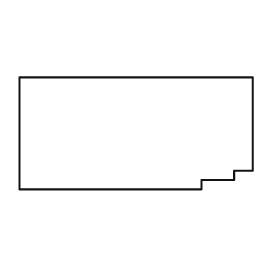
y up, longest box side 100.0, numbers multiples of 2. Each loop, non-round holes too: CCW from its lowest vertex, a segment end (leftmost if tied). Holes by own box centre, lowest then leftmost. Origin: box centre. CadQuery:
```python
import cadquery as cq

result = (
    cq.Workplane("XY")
    .moveTo(-50.0, -24.0)
    .lineTo(28.0, -24.0)
    .lineTo(28.0, -20.0)
    .lineTo(42.0, -20.0)
    .lineTo(42.0, -16.0)
    .lineTo(50.0, -16.0)
    .lineTo(50.0, 24.0)
    .lineTo(-50.0, 24.0)
    .close()
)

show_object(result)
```